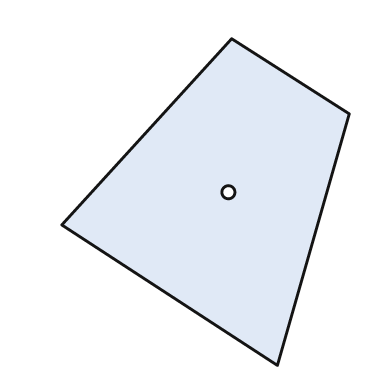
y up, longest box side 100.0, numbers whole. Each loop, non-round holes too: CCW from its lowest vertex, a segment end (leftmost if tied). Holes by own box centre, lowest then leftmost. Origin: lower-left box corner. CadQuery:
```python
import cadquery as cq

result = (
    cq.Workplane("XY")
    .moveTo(66.0, 0.0)
    .lineTo(88.0, 77.0)
    .lineTo(52.0, 100.0)
    .lineTo(0.0, 43.0)
    .close()
    .moveTo(51.0, 53.0)
    .circle(2.0)
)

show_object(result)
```